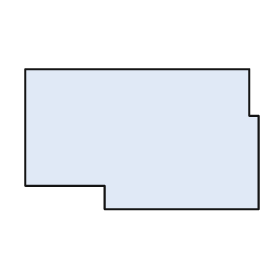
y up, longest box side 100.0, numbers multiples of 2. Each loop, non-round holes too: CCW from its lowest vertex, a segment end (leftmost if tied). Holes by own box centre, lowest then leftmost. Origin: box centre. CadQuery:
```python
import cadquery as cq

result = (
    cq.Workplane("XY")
    .moveTo(-16.0, -30.0)
    .lineTo(50.0, -30.0)
    .lineTo(50.0, 10.0)
    .lineTo(46.0, 10.0)
    .lineTo(46.0, 30.0)
    .lineTo(-50.0, 30.0)
    .lineTo(-50.0, -20.0)
    .lineTo(-16.0, -20.0)
    .close()
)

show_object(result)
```